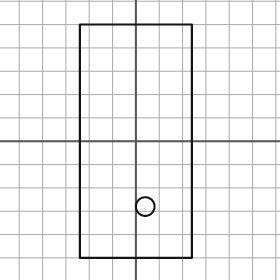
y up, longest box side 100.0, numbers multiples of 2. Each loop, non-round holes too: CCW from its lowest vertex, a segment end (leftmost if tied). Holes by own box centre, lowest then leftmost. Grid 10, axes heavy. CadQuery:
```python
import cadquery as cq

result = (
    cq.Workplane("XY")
    .moveTo(-24.0, -50.0)
    .lineTo(24.0, -50.0)
    .lineTo(24.0, 50.0)
    .lineTo(-24.0, 50.0)
    .close()
    .moveTo(4.0, -28.0)
    .circle(4.0)
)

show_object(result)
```